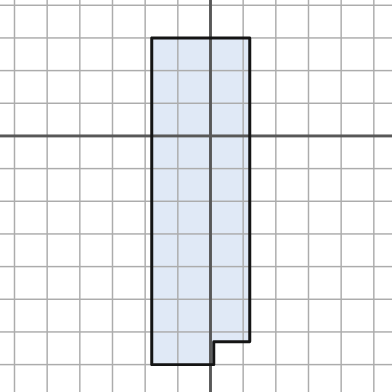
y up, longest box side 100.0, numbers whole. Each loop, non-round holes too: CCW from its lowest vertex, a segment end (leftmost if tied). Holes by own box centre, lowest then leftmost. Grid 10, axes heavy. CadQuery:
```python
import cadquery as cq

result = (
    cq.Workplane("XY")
    .moveTo(-18.0, -70.0)
    .lineTo(1.0, -70.0)
    .lineTo(1.0, -63.0)
    .lineTo(12.0, -63.0)
    .lineTo(12.0, 30.0)
    .lineTo(-18.0, 30.0)
    .close()
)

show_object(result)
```